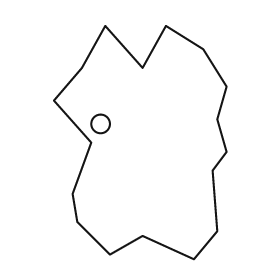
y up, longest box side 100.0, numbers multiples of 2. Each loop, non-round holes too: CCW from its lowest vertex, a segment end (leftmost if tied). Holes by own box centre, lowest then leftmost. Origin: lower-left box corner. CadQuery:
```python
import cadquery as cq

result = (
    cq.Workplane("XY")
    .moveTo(60.0, 0.0)
    .lineTo(70.0, 12.0)
    .lineTo(68.0, 38.0)
    .lineTo(74.0, 46.0)
    .lineTo(70.0, 60.0)
    .lineTo(74.0, 74.0)
    .lineTo(64.0, 90.0)
    .lineTo(48.0, 100.0)
    .lineTo(38.0, 82.0)
    .lineTo(22.0, 100.0)
    .lineTo(12.0, 82.0)
    .lineTo(0.0, 68.0)
    .lineTo(16.0, 50.0)
    .lineTo(8.0, 28.0)
    .lineTo(10.0, 16.0)
    .lineTo(24.0, 2.0)
    .lineTo(38.0, 10.0)
    .close()
    .moveTo(20.0, 58.0)
    .circle(4.0)
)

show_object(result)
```